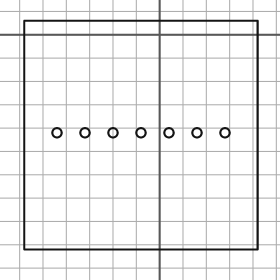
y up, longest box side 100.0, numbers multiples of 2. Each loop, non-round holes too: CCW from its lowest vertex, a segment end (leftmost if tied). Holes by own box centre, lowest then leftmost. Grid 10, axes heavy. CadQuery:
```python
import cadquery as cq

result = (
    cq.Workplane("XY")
    .moveTo(-58.0, -92.0)
    .lineTo(42.0, -92.0)
    .lineTo(42.0, 6.0)
    .lineTo(-58.0, 6.0)
    .close()
    .moveTo(-44.0, -42.0)
    .circle(2.0)
    .moveTo(-32.0, -42.0)
    .circle(2.0)
    .moveTo(-20.0, -42.0)
    .circle(2.0)
    .moveTo(-8.0, -42.0)
    .circle(2.0)
    .moveTo(4.0, -42.0)
    .circle(2.0)
    .moveTo(16.0, -42.0)
    .circle(2.0)
    .moveTo(28.0, -42.0)
    .circle(2.0)
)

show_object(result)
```